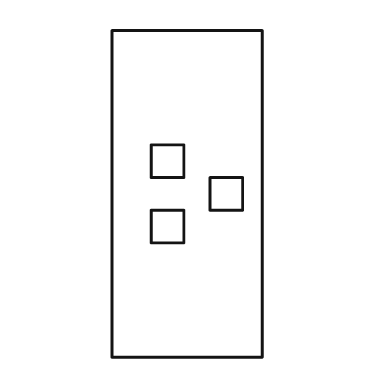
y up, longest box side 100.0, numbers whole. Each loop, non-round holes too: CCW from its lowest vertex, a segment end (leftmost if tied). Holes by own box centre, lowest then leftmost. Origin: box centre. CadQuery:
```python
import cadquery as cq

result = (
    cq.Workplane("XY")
    .moveTo(-23.0, -50.0)
    .lineTo(23.0, -50.0)
    .lineTo(23.0, 50.0)
    .lineTo(-23.0, 50.0)
    .close()
    .moveTo(-11.0, -15.0)
    .lineTo(-1.0, -15.0)
    .lineTo(-1.0, -5.0)
    .lineTo(-11.0, -5.0)
    .close()
    .moveTo(7.0, -5.0)
    .lineTo(17.0, -5.0)
    .lineTo(17.0, 5.0)
    .lineTo(7.0, 5.0)
    .close()
    .moveTo(-11.0, 5.0)
    .lineTo(-1.0, 5.0)
    .lineTo(-1.0, 15.0)
    .lineTo(-11.0, 15.0)
    .close()
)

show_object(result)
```